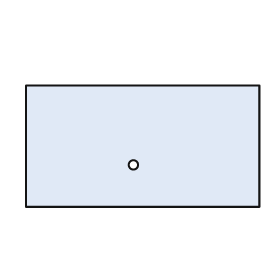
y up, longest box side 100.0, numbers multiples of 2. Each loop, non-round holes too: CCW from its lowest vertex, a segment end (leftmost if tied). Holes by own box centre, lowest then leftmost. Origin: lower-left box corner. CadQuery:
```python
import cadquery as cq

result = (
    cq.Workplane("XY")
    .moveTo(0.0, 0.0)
    .lineTo(100.0, 0.0)
    .lineTo(100.0, 52.0)
    .lineTo(0.0, 52.0)
    .close()
    .moveTo(46.0, 18.0)
    .circle(2.0)
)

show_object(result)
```